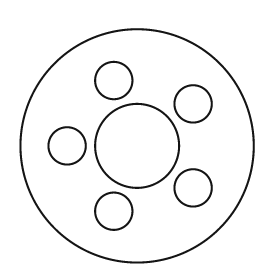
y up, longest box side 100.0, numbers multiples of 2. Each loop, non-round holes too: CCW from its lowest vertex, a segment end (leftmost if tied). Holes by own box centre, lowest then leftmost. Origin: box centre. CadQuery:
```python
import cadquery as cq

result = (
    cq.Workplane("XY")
    .moveTo(0.0, 0.0)
    .circle(50.0)
    .moveTo(-10.0, -28.0)
    .circle(8.0)
    .moveTo(24.0, -18.0)
    .circle(8.0)
    .moveTo(-30.0, 0.0)
    .circle(8.0)
    .moveTo(0.0, 0.0)
    .circle(18.0)
    .moveTo(24.0, 18.0)
    .circle(8.0)
    .moveTo(-10.0, 28.0)
    .circle(8.0)
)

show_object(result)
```